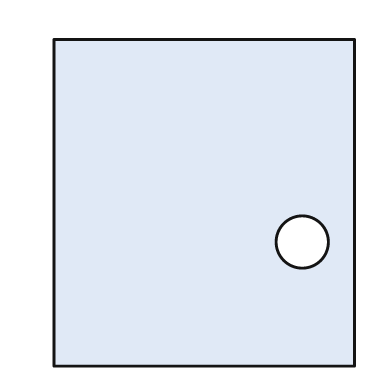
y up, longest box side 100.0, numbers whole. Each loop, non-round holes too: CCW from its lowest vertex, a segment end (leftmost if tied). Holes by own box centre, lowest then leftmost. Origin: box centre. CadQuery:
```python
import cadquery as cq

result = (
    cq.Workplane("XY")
    .moveTo(-46.0, -50.0)
    .lineTo(46.0, -50.0)
    .lineTo(46.0, 50.0)
    .lineTo(-46.0, 50.0)
    .close()
    .moveTo(30.0, -12.0)
    .circle(8.0)
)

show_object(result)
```